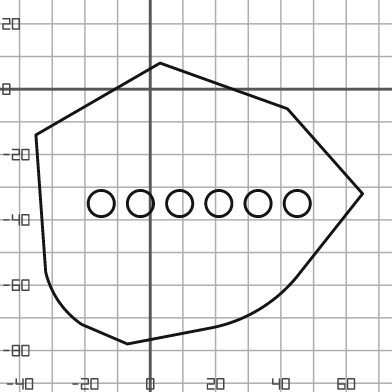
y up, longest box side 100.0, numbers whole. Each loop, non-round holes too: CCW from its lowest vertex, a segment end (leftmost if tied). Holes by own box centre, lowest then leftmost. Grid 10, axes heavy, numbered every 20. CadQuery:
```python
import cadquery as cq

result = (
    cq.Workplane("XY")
    .moveTo(-7.0, -78.0)
    .lineTo(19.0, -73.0)
    .threePointArc((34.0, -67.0), (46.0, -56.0))
    .lineTo(65.0, -32.0)
    .lineTo(42.0, -6.0)
    .lineTo(3.0, 8.0)
    .lineTo(-35.0, -14.0)
    .lineTo(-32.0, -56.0)
    .threePointArc((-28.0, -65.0), (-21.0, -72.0))
    .close()
    .moveTo(-15.0, -35.0)
    .circle(4.0)
    .moveTo(-3.0, -35.0)
    .circle(4.0)
    .moveTo(9.0, -35.0)
    .circle(4.0)
    .moveTo(21.0, -35.0)
    .circle(4.0)
    .moveTo(33.0, -35.0)
    .circle(4.0)
    .moveTo(45.0, -35.0)
    .circle(4.0)
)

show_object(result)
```